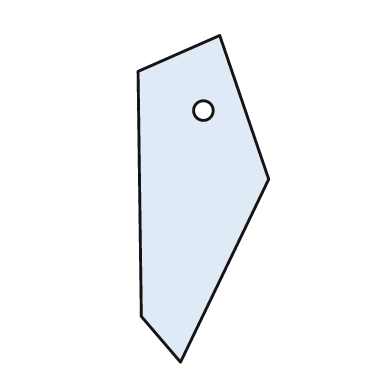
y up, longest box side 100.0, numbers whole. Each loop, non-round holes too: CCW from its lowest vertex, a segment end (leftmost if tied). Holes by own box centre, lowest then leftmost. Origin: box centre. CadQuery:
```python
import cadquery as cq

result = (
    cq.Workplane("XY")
    .moveTo(-7.0, -50.0)
    .lineTo(20.0, 6.0)
    .lineTo(5.0, 50.0)
    .lineTo(-20.0, 39.0)
    .lineTo(-19.0, -36.0)
    .close()
    .moveTo(0.0, 27.0)
    .circle(3.0)
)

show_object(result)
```